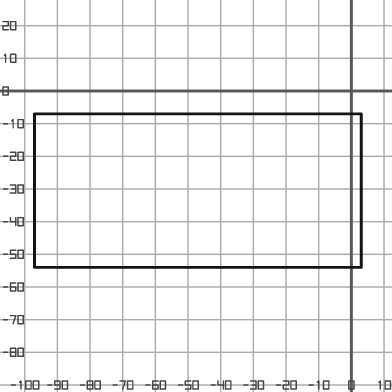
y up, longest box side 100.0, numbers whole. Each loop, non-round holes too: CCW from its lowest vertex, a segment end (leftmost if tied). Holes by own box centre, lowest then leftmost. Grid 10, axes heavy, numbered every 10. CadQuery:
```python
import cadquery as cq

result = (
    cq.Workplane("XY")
    .moveTo(-97.0, -54.0)
    .lineTo(3.0, -54.0)
    .lineTo(3.0, -7.0)
    .lineTo(-97.0, -7.0)
    .close()
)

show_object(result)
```